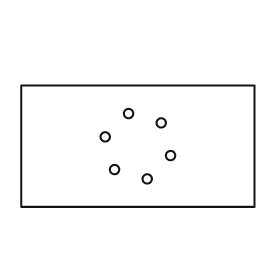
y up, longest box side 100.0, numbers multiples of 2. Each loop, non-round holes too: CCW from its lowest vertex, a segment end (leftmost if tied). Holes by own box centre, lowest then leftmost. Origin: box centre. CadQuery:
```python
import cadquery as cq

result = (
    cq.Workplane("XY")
    .moveTo(-50.0, -26.0)
    .lineTo(50.0, -26.0)
    .lineTo(50.0, 26.0)
    .lineTo(-50.0, 26.0)
    .close()
    .moveTo(4.0, -14.0)
    .circle(2.0)
    .moveTo(-10.0, -10.0)
    .circle(2.0)
    .moveTo(14.0, -4.0)
    .circle(2.0)
    .moveTo(-14.0, 4.0)
    .circle(2.0)
    .moveTo(10.0, 10.0)
    .circle(2.0)
    .moveTo(-4.0, 14.0)
    .circle(2.0)
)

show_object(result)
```